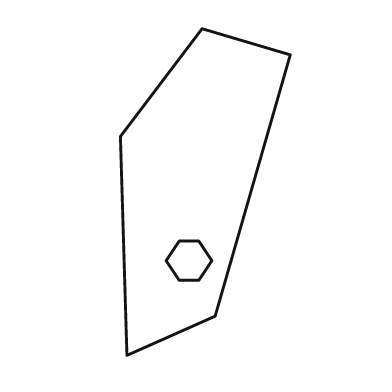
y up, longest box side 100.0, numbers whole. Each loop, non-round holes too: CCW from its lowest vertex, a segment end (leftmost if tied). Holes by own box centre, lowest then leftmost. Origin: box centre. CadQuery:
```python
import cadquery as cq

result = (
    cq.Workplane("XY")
    .moveTo(-24.0, -50.0)
    .lineTo(3.0, -38.0)
    .lineTo(26.0, 42.0)
    .lineTo(-1.0, 50.0)
    .lineTo(-26.0, 17.0)
    .close()
    .moveTo(-8.0, -27.0)
    .lineTo(-2.0, -27.0)
    .lineTo(2.0, -21.0)
    .lineTo(-2.0, -15.0)
    .lineTo(-8.0, -15.0)
    .lineTo(-12.0, -21.0)
    .close()
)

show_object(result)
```